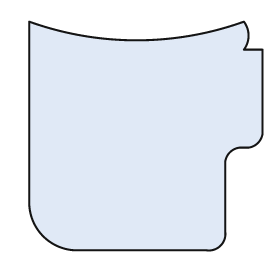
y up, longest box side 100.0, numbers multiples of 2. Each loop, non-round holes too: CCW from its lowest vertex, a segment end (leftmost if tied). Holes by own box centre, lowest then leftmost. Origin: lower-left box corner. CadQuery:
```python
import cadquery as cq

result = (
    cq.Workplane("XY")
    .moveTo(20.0, 0.0)
    .lineTo(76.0, 0.0)
    .threePointArc((82.0, 2.0), (84.0, 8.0))
    .lineTo(84.0, 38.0)
    .threePointArc((86.0, 42.0), (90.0, 44.0))
    .lineTo(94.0, 44.0)
    .threePointArc((98.0, 46.0), (100.0, 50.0))
    .lineTo(100.0, 86.0)
    .lineTo(92.0, 86.0)
    .threePointArc((94.0, 92.0), (92.0, 98.0))
    .threePointArc((46.0, 90.0), (0.0, 98.0))
    .lineTo(0.0, 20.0)
    .threePointArc((6.0, 6.0), (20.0, 0.0))
    .close()
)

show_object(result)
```